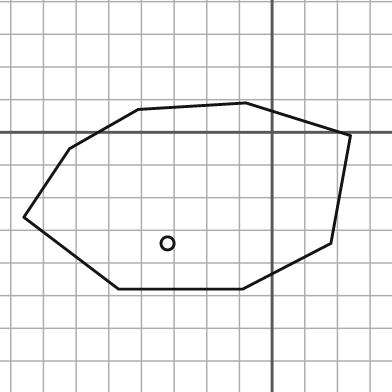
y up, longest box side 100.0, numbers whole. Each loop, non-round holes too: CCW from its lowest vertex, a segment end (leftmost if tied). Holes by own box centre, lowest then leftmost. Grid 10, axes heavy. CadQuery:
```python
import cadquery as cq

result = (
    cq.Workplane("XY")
    .moveTo(-47.0, -48.0)
    .lineTo(-9.0, -48.0)
    .lineTo(18.0, -34.0)
    .lineTo(24.0, -1.0)
    .lineTo(-8.0, 9.0)
    .lineTo(-41.0, 7.0)
    .lineTo(-62.0, -5.0)
    .lineTo(-76.0, -26.0)
    .close()
    .moveTo(-32.0, -34.0)
    .circle(2.0)
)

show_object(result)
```